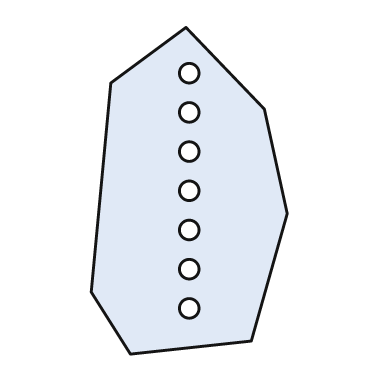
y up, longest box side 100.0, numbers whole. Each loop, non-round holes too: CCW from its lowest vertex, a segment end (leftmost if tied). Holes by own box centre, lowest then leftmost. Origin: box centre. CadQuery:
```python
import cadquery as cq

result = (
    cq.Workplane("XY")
    .moveTo(-18.0, -50.0)
    .lineTo(19.0, -46.0)
    .lineTo(30.0, -7.0)
    .lineTo(23.0, 25.0)
    .lineTo(-1.0, 50.0)
    .lineTo(-24.0, 33.0)
    .lineTo(-30.0, -31.0)
    .close()
    .moveTo(0.0, -36.0)
    .circle(3.0)
    .moveTo(0.0, -24.0)
    .circle(3.0)
    .moveTo(0.0, -12.0)
    .circle(3.0)
    .moveTo(0.0, 0.0)
    .circle(3.0)
    .moveTo(0.0, 12.0)
    .circle(3.0)
    .moveTo(0.0, 24.0)
    .circle(3.0)
    .moveTo(0.0, 36.0)
    .circle(3.0)
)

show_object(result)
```